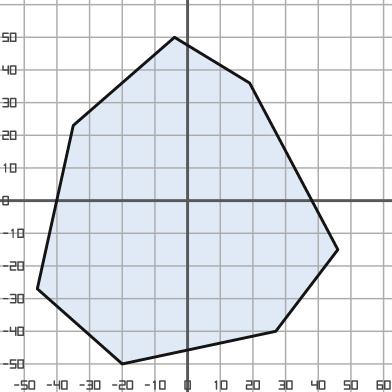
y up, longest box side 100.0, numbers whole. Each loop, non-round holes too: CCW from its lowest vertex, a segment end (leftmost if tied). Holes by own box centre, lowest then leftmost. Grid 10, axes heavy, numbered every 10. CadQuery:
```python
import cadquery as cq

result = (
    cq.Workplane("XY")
    .moveTo(-20.0, -50.0)
    .lineTo(27.0, -40.0)
    .lineTo(46.0, -15.0)
    .lineTo(19.0, 36.0)
    .lineTo(-4.0, 50.0)
    .lineTo(-35.0, 23.0)
    .lineTo(-46.0, -27.0)
    .close()
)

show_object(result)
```